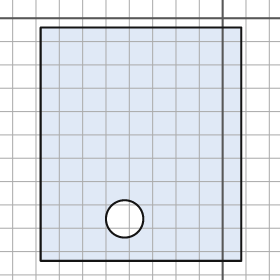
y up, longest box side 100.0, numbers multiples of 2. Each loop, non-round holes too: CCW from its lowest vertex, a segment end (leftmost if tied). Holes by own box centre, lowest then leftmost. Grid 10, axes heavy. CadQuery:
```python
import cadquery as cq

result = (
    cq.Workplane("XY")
    .moveTo(-78.0, -104.0)
    .lineTo(8.0, -104.0)
    .lineTo(8.0, -4.0)
    .lineTo(-78.0, -4.0)
    .close()
    .moveTo(-42.0, -86.0)
    .circle(8.0)
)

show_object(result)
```